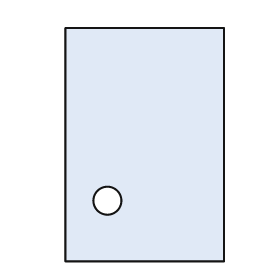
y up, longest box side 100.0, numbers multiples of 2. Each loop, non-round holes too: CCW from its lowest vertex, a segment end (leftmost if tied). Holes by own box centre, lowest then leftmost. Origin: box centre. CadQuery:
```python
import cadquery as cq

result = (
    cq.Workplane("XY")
    .moveTo(-34.0, -50.0)
    .lineTo(34.0, -50.0)
    .lineTo(34.0, 50.0)
    .lineTo(-34.0, 50.0)
    .close()
    .moveTo(-16.0, -24.0)
    .circle(6.0)
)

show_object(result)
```